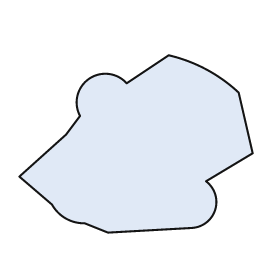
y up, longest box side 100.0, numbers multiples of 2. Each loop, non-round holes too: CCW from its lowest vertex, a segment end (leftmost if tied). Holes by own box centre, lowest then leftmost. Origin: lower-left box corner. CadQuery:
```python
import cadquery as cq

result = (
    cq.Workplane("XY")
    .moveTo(38.0, 0.0)
    .lineTo(74.0, 2.0)
    .threePointArc((84.0, 10.0), (80.0, 22.0))
    .lineTo(100.0, 34.0)
    .lineTo(94.0, 60.0)
    .threePointArc((80.0, 70.0), (64.0, 76.0))
    .lineTo(46.0, 64.0)
    .threePointArc((30.0, 66.0), (26.0, 50.0))
    .lineTo(20.0, 42.0)
    .lineTo(0.0, 24.0)
    .lineTo(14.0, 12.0)
    .threePointArc((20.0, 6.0), (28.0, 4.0))
    .close()
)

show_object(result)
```